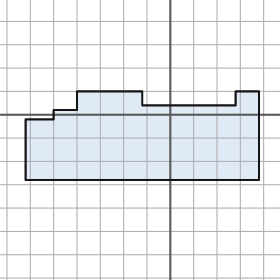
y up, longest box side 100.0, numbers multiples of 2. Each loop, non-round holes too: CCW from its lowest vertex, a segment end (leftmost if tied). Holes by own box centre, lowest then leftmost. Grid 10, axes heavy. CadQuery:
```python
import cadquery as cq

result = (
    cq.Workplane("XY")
    .moveTo(-62.0, -28.0)
    .lineTo(38.0, -28.0)
    .lineTo(38.0, 10.0)
    .lineTo(28.0, 10.0)
    .lineTo(28.0, 4.0)
    .lineTo(-12.0, 4.0)
    .lineTo(-12.0, 10.0)
    .lineTo(-40.0, 10.0)
    .lineTo(-40.0, 2.0)
    .lineTo(-50.0, 2.0)
    .lineTo(-50.0, -2.0)
    .lineTo(-62.0, -2.0)
    .close()
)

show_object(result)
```